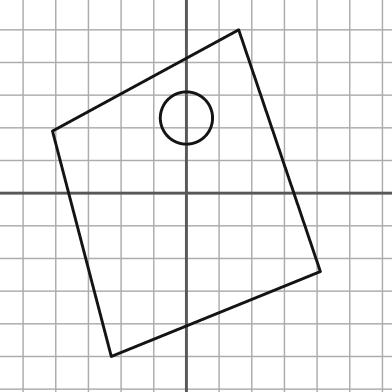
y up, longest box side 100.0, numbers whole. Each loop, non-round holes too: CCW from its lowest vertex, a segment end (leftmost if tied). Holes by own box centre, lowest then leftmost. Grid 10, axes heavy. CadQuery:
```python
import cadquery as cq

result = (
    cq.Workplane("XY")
    .moveTo(-23.0, -50.0)
    .lineTo(41.0, -24.0)
    .lineTo(16.0, 50.0)
    .lineTo(-41.0, 19.0)
    .close()
    .moveTo(0.0, 23.0)
    .circle(8.0)
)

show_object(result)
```